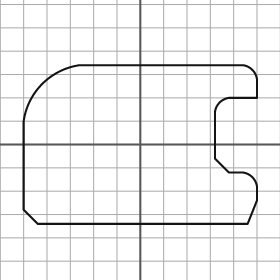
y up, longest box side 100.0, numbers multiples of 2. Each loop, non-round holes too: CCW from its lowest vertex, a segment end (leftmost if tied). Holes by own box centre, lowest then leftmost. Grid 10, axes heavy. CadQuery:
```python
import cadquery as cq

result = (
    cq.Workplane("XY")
    .moveTo(-44.0, -34.0)
    .lineTo(46.0, -34.0)
    .lineTo(50.0, -24.0)
    .lineTo(50.0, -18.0)
    .threePointArc((48.0, -14.0), (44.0, -12.0))
    .lineTo(38.0, -12.0)
    .lineTo(32.0, -6.0)
    .lineTo(32.0, 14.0)
    .threePointArc((34.0, 18.0), (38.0, 20.0))
    .lineTo(50.0, 20.0)
    .lineTo(50.0, 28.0)
    .threePointArc((48.0, 32.0), (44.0, 34.0))
    .lineTo(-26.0, 34.0)
    .threePointArc((-42.0, 26.0), (-50.0, 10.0))
    .lineTo(-50.0, -28.0)
    .close()
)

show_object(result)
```